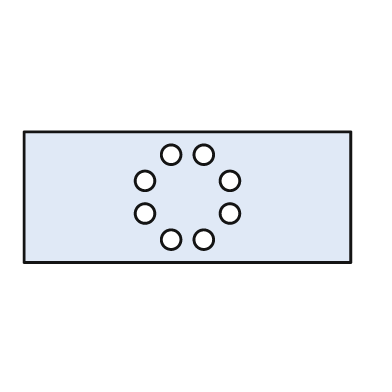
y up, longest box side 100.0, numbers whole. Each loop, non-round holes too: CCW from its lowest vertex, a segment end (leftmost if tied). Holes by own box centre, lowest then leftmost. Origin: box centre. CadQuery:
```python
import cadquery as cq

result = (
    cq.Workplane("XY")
    .moveTo(-50.0, -20.0)
    .lineTo(50.0, -20.0)
    .lineTo(50.0, 20.0)
    .lineTo(-50.0, 20.0)
    .close()
    .moveTo(-5.0, -13.0)
    .circle(3.0)
    .moveTo(5.0, -13.0)
    .circle(3.0)
    .moveTo(-13.0, -5.0)
    .circle(3.0)
    .moveTo(13.0, -5.0)
    .circle(3.0)
    .moveTo(-13.0, 5.0)
    .circle(3.0)
    .moveTo(13.0, 5.0)
    .circle(3.0)
    .moveTo(-5.0, 13.0)
    .circle(3.0)
    .moveTo(5.0, 13.0)
    .circle(3.0)
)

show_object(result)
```